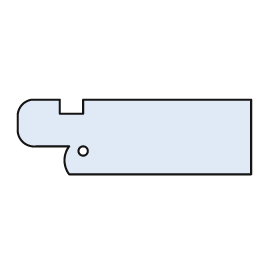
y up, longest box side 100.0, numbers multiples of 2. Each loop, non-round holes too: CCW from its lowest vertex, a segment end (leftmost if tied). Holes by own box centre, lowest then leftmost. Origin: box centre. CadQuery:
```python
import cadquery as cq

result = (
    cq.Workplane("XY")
    .moveTo(-28.0, -16.0)
    .lineTo(50.0, -16.0)
    .lineTo(50.0, 16.0)
    .lineTo(-22.0, 16.0)
    .lineTo(-22.0, 10.0)
    .lineTo(-32.0, 10.0)
    .lineTo(-32.0, 16.0)
    .lineTo(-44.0, 16.0)
    .threePointArc((-48.0, 14.0), (-50.0, 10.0))
    .lineTo(-50.0, 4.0)
    .threePointArc((-48.0, -2.0), (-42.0, -4.0))
    .lineTo(-28.0, -4.0)
    .threePointArc((-30.0, -10.0), (-28.0, -16.0))
    .close()
    .moveTo(-22.0, -6.0)
    .circle(2.0)
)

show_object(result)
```